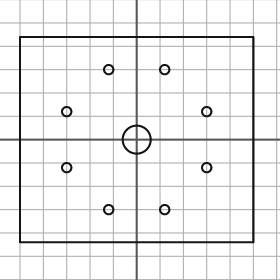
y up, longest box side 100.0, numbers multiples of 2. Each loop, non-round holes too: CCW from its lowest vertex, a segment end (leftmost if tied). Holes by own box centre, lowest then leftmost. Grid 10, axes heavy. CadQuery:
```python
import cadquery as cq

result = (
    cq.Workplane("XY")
    .moveTo(-50.0, -44.0)
    .lineTo(50.0, -44.0)
    .lineTo(50.0, 44.0)
    .lineTo(-50.0, 44.0)
    .close()
    .moveTo(-12.0, -30.0)
    .circle(2.0)
    .moveTo(12.0, -30.0)
    .circle(2.0)
    .moveTo(-30.0, -12.0)
    .circle(2.0)
    .moveTo(30.0, -12.0)
    .circle(2.0)
    .moveTo(0.0, 0.0)
    .circle(6.0)
    .moveTo(-30.0, 12.0)
    .circle(2.0)
    .moveTo(30.0, 12.0)
    .circle(2.0)
    .moveTo(-12.0, 30.0)
    .circle(2.0)
    .moveTo(12.0, 30.0)
    .circle(2.0)
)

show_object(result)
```